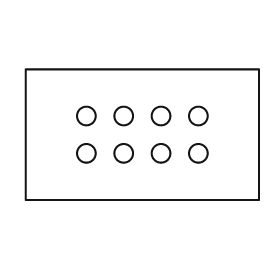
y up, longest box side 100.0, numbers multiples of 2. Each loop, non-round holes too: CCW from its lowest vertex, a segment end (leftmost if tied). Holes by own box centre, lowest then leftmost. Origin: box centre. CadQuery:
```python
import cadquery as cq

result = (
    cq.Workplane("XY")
    .moveTo(-50.0, -28.0)
    .lineTo(50.0, -28.0)
    .lineTo(50.0, 28.0)
    .lineTo(-50.0, 28.0)
    .close()
    .moveTo(-24.0, -8.0)
    .circle(4.0)
    .moveTo(-8.0, -8.0)
    .circle(4.0)
    .moveTo(8.0, -8.0)
    .circle(4.0)
    .moveTo(24.0, -8.0)
    .circle(4.0)
    .moveTo(-24.0, 8.0)
    .circle(4.0)
    .moveTo(-8.0, 8.0)
    .circle(4.0)
    .moveTo(8.0, 8.0)
    .circle(4.0)
    .moveTo(24.0, 8.0)
    .circle(4.0)
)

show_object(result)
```